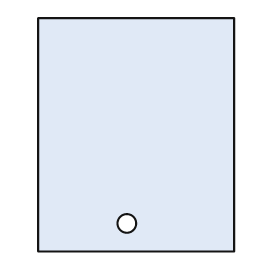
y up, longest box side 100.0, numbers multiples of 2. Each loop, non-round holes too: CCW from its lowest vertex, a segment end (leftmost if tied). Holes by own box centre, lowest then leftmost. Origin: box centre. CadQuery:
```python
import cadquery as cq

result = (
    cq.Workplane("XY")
    .moveTo(-42.0, -50.0)
    .lineTo(42.0, -50.0)
    .lineTo(42.0, 50.0)
    .lineTo(-42.0, 50.0)
    .close()
    .moveTo(-4.0, -38.0)
    .circle(4.0)
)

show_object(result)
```